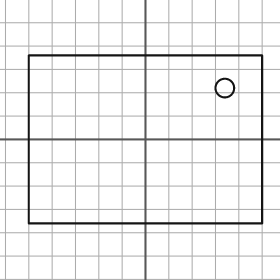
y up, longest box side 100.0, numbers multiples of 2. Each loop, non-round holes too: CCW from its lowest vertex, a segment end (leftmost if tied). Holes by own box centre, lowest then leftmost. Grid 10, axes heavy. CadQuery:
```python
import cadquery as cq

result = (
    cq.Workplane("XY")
    .moveTo(-50.0, -36.0)
    .lineTo(50.0, -36.0)
    .lineTo(50.0, 36.0)
    .lineTo(-50.0, 36.0)
    .close()
    .moveTo(34.0, 22.0)
    .circle(4.0)
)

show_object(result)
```